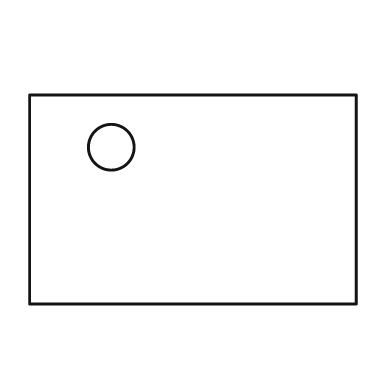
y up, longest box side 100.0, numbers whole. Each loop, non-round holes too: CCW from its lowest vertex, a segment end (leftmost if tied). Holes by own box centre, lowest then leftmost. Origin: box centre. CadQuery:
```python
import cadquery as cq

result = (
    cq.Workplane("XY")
    .moveTo(-50.0, -32.0)
    .lineTo(50.0, -32.0)
    .lineTo(50.0, 32.0)
    .lineTo(-50.0, 32.0)
    .close()
    .moveTo(-25.0, 16.0)
    .circle(7.0)
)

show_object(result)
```